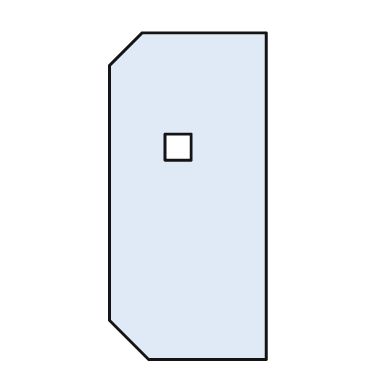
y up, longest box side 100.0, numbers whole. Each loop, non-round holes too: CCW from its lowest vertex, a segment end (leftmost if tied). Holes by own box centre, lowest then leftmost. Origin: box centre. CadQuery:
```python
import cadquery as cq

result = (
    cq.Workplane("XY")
    .moveTo(-12.0, -50.0)
    .lineTo(24.0, -50.0)
    .lineTo(24.0, 50.0)
    .lineTo(-14.0, 50.0)
    .lineTo(-24.0, 40.0)
    .lineTo(-24.0, -38.0)
    .close()
    .moveTo(-7.0, 11.0)
    .lineTo(1.0, 11.0)
    .lineTo(1.0, 19.0)
    .lineTo(-7.0, 19.0)
    .close()
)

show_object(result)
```